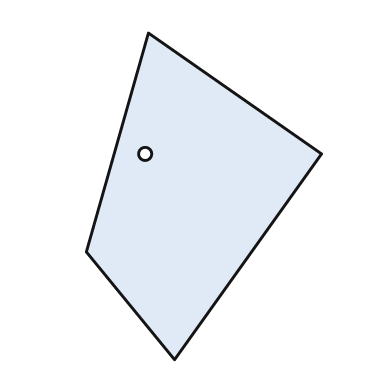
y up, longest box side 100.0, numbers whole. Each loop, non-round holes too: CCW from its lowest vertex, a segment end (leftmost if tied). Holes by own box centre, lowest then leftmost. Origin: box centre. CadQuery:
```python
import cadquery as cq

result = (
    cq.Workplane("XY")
    .moveTo(-9.0, -50.0)
    .lineTo(36.0, 13.0)
    .lineTo(-17.0, 50.0)
    .lineTo(-36.0, -17.0)
    .close()
    .moveTo(-18.0, 13.0)
    .circle(2.0)
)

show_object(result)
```